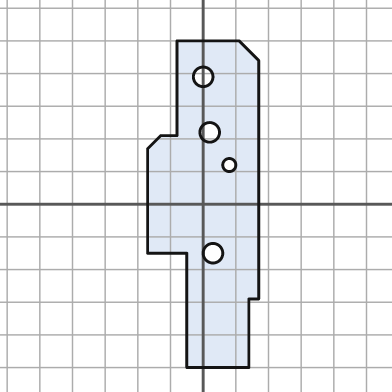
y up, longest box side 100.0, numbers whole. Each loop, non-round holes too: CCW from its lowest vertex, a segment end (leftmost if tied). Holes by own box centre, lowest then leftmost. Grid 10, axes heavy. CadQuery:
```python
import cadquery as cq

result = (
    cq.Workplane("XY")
    .moveTo(-5.0, -50.0)
    .lineTo(14.0, -50.0)
    .lineTo(14.0, -29.0)
    .lineTo(17.0, -29.0)
    .lineTo(17.0, 44.0)
    .lineTo(11.0, 50.0)
    .lineTo(-8.0, 50.0)
    .lineTo(-8.0, 21.0)
    .lineTo(-13.0, 21.0)
    .lineTo(-17.0, 17.0)
    .lineTo(-17.0, -15.0)
    .lineTo(-5.0, -15.0)
    .close()
    .moveTo(3.0, -15.0)
    .circle(3.0)
    .moveTo(8.0, 12.0)
    .circle(2.0)
    .moveTo(2.0, 22.0)
    .circle(3.0)
    .moveTo(0.0, 39.0)
    .circle(3.0)
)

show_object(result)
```